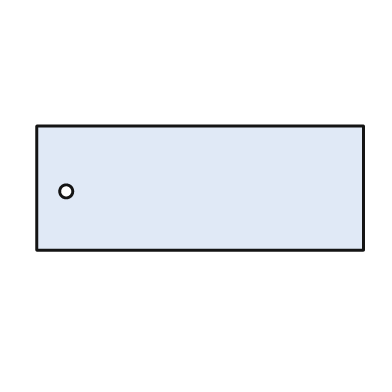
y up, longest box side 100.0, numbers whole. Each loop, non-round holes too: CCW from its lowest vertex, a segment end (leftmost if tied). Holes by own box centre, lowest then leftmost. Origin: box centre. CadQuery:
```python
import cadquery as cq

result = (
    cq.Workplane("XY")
    .moveTo(-50.0, -19.0)
    .lineTo(50.0, -19.0)
    .lineTo(50.0, 19.0)
    .lineTo(-50.0, 19.0)
    .close()
    .moveTo(-41.0, -1.0)
    .circle(2.0)
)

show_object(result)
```